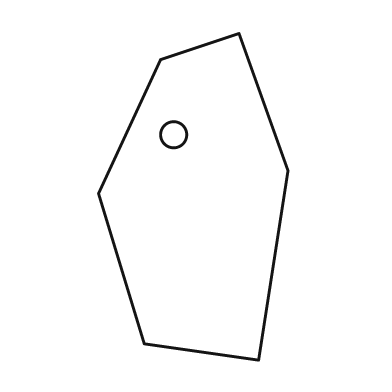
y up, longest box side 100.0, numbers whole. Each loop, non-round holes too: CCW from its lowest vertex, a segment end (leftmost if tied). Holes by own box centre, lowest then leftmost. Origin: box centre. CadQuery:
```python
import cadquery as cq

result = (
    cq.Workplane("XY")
    .moveTo(20.0, -50.0)
    .lineTo(29.0, 8.0)
    .lineTo(14.0, 50.0)
    .lineTo(-10.0, 42.0)
    .lineTo(-29.0, 1.0)
    .lineTo(-15.0, -45.0)
    .close()
    .moveTo(-6.0, 19.0)
    .circle(4.0)
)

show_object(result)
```